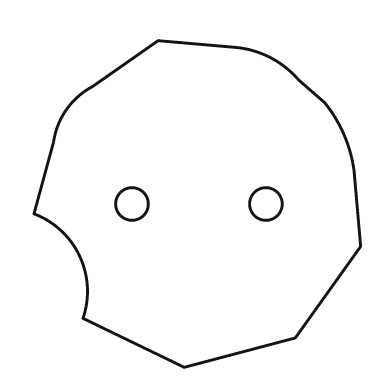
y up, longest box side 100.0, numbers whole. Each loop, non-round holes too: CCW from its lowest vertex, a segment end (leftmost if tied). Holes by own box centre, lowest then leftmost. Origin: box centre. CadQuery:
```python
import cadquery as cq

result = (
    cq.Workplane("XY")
    .moveTo(-4.0, -50.0)
    .lineTo(30.0, -41.0)
    .lineTo(50.0, -13.0)
    .lineTo(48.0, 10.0)
    .threePointArc((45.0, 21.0), (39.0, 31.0))
    .lineTo(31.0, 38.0)
    .threePointArc((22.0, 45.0), (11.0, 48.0))
    .lineTo(-12.0, 50.0)
    .lineTo(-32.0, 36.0)
    .threePointArc((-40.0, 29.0), (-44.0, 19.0))
    .lineTo(-50.0, -3.0)
    .threePointArc((-36.0, -16.0), (-35.0, -35.0))
    .close()
    .moveTo(-20.0, 0.0)
    .circle(5.0)
    .moveTo(21.0, 0.0)
    .circle(5.0)
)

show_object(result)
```